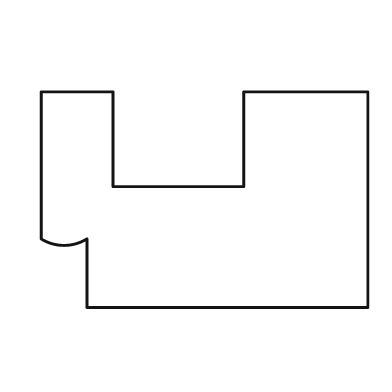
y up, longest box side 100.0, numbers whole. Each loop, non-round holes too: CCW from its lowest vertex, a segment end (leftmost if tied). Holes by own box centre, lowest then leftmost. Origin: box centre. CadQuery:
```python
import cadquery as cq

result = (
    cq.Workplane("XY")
    .moveTo(-36.0, -33.0)
    .lineTo(50.0, -33.0)
    .lineTo(50.0, 33.0)
    .lineTo(12.0, 33.0)
    .lineTo(12.0, 4.0)
    .lineTo(-28.0, 4.0)
    .lineTo(-28.0, 33.0)
    .lineTo(-50.0, 33.0)
    .lineTo(-50.0, -12.0)
    .threePointArc((-43.0, -14.0), (-36.0, -12.0))
    .close()
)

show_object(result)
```